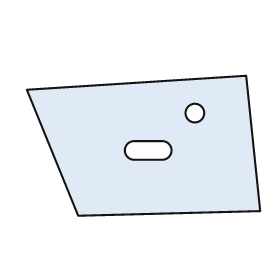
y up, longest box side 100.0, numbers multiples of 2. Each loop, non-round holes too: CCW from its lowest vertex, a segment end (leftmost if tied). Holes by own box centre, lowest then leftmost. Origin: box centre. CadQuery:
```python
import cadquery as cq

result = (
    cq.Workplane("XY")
    .moveTo(-28.0, -30.0)
    .lineTo(50.0, -28.0)
    .lineTo(44.0, 30.0)
    .lineTo(-50.0, 24.0)
    .close()
    .moveTo(-4.0, -6.0)
    .lineTo(8.0, -6.0)
    .threePointArc((12.0, -2.0), (8.0, 2.0))
    .lineTo(-4.0, 2.0)
    .threePointArc((-8.0, -2.0), (-4.0, -6.0))
    .close()
    .moveTo(22.0, 14.0)
    .circle(4.0)
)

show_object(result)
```